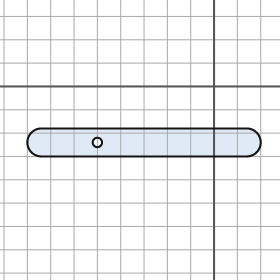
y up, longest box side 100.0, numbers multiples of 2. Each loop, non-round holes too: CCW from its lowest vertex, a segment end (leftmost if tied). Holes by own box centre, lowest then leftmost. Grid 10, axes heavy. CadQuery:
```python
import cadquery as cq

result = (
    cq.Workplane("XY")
    .moveTo(-74.0, -30.0)
    .lineTo(14.0, -30.0)
    .threePointArc((20.0, -24.0), (14.0, -18.0))
    .lineTo(-74.0, -18.0)
    .threePointArc((-80.0, -24.0), (-74.0, -30.0))
    .close()
    .moveTo(-50.0, -24.0)
    .circle(2.0)
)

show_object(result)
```